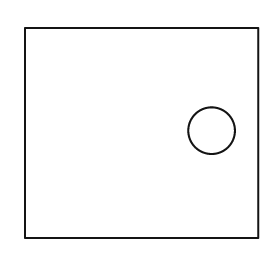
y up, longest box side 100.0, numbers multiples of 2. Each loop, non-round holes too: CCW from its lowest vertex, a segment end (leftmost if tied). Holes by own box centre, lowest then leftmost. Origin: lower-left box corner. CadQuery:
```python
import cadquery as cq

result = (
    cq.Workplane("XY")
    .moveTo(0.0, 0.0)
    .lineTo(100.0, 0.0)
    .lineTo(100.0, 90.0)
    .lineTo(0.0, 90.0)
    .close()
    .moveTo(80.0, 46.0)
    .circle(10.0)
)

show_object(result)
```